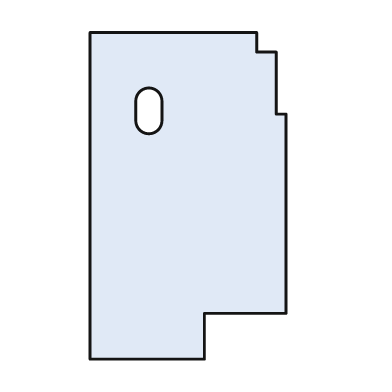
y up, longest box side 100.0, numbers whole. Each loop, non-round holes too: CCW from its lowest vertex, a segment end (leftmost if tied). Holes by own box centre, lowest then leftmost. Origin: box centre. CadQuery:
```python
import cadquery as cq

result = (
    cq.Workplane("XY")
    .moveTo(-30.0, -50.0)
    .lineTo(5.0, -50.0)
    .lineTo(5.0, -36.0)
    .lineTo(30.0, -36.0)
    .lineTo(30.0, 25.0)
    .lineTo(27.0, 25.0)
    .lineTo(27.0, 44.0)
    .lineTo(21.0, 44.0)
    .lineTo(21.0, 50.0)
    .lineTo(-30.0, 50.0)
    .close()
    .moveTo(-16.0, 23.0)
    .threePointArc((-12.0, 19.0), (-8.0, 23.0))
    .lineTo(-8.0, 29.0)
    .threePointArc((-12.0, 33.0), (-16.0, 29.0))
    .close()
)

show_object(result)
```